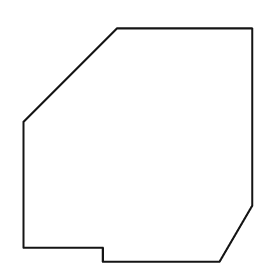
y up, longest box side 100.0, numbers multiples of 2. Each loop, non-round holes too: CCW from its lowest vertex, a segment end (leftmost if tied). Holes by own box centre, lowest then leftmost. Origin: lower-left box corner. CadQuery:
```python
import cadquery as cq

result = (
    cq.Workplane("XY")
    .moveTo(34.0, 0.0)
    .lineTo(84.0, 0.0)
    .lineTo(98.0, 24.0)
    .lineTo(98.0, 100.0)
    .lineTo(40.0, 100.0)
    .lineTo(0.0, 60.0)
    .lineTo(0.0, 6.0)
    .lineTo(34.0, 6.0)
    .close()
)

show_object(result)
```